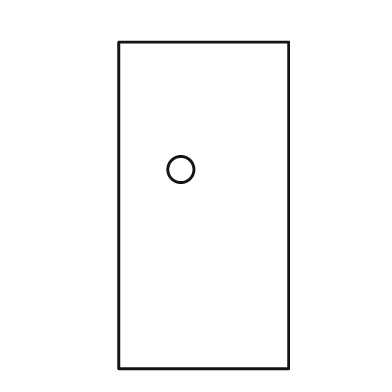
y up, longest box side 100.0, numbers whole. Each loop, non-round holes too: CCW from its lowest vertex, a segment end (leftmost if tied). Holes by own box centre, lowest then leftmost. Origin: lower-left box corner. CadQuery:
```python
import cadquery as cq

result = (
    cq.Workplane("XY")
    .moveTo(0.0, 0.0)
    .lineTo(52.0, 0.0)
    .lineTo(52.0, 100.0)
    .lineTo(0.0, 100.0)
    .close()
    .moveTo(19.0, 61.0)
    .circle(4.0)
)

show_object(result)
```